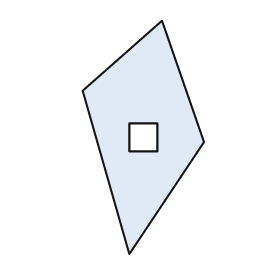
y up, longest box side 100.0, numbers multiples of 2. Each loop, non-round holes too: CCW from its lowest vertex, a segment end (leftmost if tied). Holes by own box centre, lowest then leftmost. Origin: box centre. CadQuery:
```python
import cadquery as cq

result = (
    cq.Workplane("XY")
    .moveTo(-6.0, -50.0)
    .lineTo(26.0, -2.0)
    .lineTo(8.0, 50.0)
    .lineTo(-26.0, 20.0)
    .close()
    .moveTo(-6.0, -6.0)
    .lineTo(6.0, -6.0)
    .lineTo(6.0, 6.0)
    .lineTo(-6.0, 6.0)
    .close()
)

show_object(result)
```